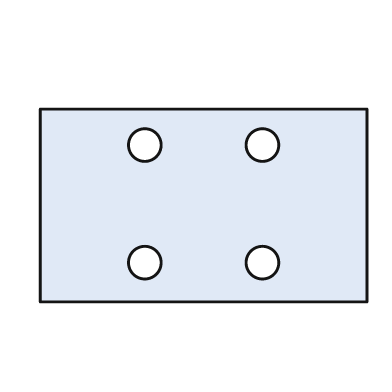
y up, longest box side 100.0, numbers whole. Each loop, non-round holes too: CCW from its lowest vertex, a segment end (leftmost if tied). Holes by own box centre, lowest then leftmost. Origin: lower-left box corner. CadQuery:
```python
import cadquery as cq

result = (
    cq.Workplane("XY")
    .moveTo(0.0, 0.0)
    .lineTo(100.0, 0.0)
    .lineTo(100.0, 59.0)
    .lineTo(0.0, 59.0)
    .close()
    .moveTo(32.0, 12.0)
    .circle(5.0)
    .moveTo(68.0, 12.0)
    .circle(5.0)
    .moveTo(32.0, 48.0)
    .circle(5.0)
    .moveTo(68.0, 48.0)
    .circle(5.0)
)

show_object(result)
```